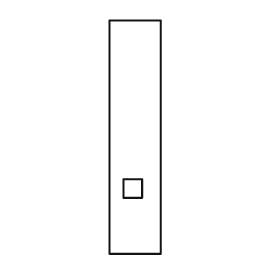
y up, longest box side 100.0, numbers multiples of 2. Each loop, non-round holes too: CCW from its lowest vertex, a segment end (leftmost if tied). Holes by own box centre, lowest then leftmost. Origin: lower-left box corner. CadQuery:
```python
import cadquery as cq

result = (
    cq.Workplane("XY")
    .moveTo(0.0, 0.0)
    .lineTo(22.0, 0.0)
    .lineTo(22.0, 100.0)
    .lineTo(0.0, 100.0)
    .close()
    .moveTo(6.0, 24.0)
    .lineTo(14.0, 24.0)
    .lineTo(14.0, 32.0)
    .lineTo(6.0, 32.0)
    .close()
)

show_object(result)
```